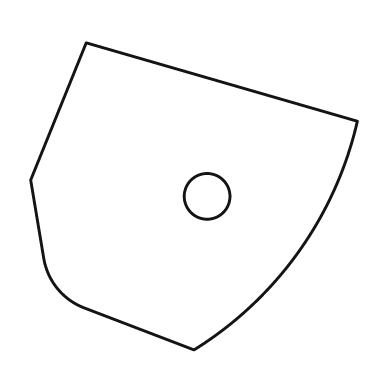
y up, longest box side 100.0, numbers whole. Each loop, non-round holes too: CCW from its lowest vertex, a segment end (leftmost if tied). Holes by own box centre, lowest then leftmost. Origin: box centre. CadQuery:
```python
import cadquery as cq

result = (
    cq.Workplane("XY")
    .moveTo(0.0, -47.0)
    .threePointArc((32.0, -17.0), (50.0, 23.0))
    .lineTo(-33.0, 47.0)
    .lineTo(-50.0, 5.0)
    .lineTo(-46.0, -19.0)
    .threePointArc((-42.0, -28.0), (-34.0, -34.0))
    .close()
    .moveTo(4.0, 0.0)
    .circle(7.0)
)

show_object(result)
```